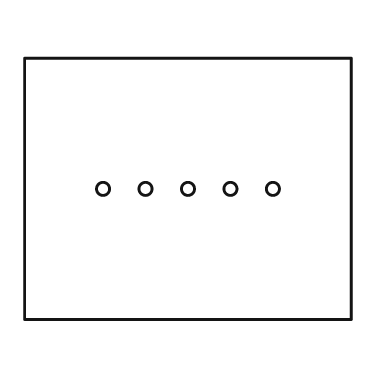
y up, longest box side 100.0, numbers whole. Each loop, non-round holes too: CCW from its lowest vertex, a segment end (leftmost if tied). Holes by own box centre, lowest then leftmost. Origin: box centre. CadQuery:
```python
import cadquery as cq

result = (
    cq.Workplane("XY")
    .moveTo(-50.0, -40.0)
    .lineTo(50.0, -40.0)
    .lineTo(50.0, 40.0)
    .lineTo(-50.0, 40.0)
    .close()
    .moveTo(-26.0, 0.0)
    .circle(2.0)
    .moveTo(-13.0, 0.0)
    .circle(2.0)
    .moveTo(0.0, 0.0)
    .circle(2.0)
    .moveTo(13.0, 0.0)
    .circle(2.0)
    .moveTo(26.0, 0.0)
    .circle(2.0)
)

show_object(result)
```